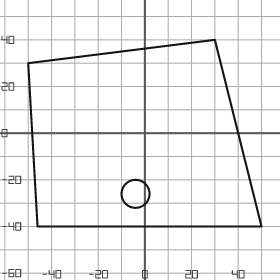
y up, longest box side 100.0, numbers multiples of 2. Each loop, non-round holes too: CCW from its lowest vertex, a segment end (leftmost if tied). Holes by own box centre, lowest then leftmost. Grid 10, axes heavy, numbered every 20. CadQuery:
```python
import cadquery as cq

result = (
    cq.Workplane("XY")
    .moveTo(-46.0, -40.0)
    .lineTo(50.0, -40.0)
    .lineTo(30.0, 40.0)
    .lineTo(-50.0, 30.0)
    .close()
    .moveTo(-4.0, -26.0)
    .circle(6.0)
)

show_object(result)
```